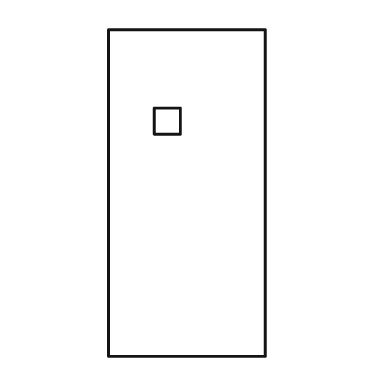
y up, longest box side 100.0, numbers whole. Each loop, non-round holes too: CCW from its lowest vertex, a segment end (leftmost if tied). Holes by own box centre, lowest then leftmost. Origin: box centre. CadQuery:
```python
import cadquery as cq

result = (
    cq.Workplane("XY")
    .moveTo(-24.0, -50.0)
    .lineTo(24.0, -50.0)
    .lineTo(24.0, 50.0)
    .lineTo(-24.0, 50.0)
    .close()
    .moveTo(-10.0, 18.0)
    .lineTo(-2.0, 18.0)
    .lineTo(-2.0, 26.0)
    .lineTo(-10.0, 26.0)
    .close()
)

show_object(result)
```